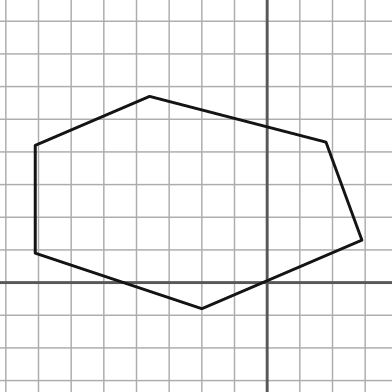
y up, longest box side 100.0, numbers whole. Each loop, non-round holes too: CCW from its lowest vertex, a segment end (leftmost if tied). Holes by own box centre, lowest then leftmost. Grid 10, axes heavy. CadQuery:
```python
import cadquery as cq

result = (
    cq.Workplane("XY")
    .moveTo(-20.0, -8.0)
    .lineTo(29.0, 13.0)
    .lineTo(18.0, 43.0)
    .lineTo(-36.0, 57.0)
    .lineTo(-71.0, 42.0)
    .lineTo(-71.0, 9.0)
    .close()
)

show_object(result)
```